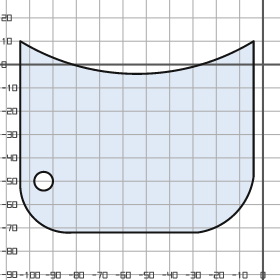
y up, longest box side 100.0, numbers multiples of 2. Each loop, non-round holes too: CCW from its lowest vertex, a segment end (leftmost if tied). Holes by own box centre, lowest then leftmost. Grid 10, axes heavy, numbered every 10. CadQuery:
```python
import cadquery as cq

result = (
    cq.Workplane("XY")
    .moveTo(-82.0, -72.0)
    .lineTo(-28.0, -72.0)
    .threePointArc((-12.0, -64.0), (-4.0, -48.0))
    .lineTo(-4.0, 10.0)
    .threePointArc((-54.0, -4.0), (-104.0, 10.0))
    .lineTo(-104.0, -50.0)
    .threePointArc((-98.0, -66.0), (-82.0, -72.0))
    .close()
    .moveTo(-94.0, -50.0)
    .circle(4.0)
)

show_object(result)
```